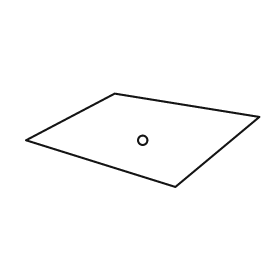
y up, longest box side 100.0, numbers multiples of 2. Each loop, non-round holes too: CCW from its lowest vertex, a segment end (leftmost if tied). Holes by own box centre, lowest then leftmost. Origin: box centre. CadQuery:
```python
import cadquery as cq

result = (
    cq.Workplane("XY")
    .moveTo(14.0, -20.0)
    .lineTo(50.0, 10.0)
    .lineTo(-12.0, 20.0)
    .lineTo(-50.0, 0.0)
    .close()
    .moveTo(0.0, 0.0)
    .circle(2.0)
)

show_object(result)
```